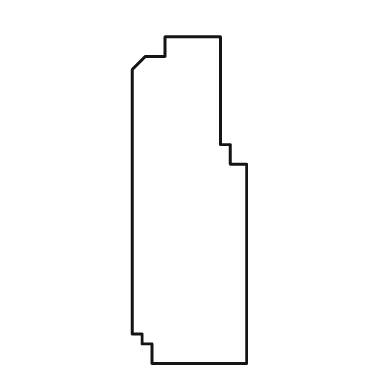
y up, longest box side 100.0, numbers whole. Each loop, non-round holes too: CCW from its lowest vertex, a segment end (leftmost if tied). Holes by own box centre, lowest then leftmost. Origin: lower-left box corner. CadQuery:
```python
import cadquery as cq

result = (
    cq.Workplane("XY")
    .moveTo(6.0, 0.0)
    .lineTo(35.0, 0.0)
    .lineTo(35.0, 61.0)
    .lineTo(30.0, 61.0)
    .lineTo(30.0, 67.0)
    .lineTo(27.0, 67.0)
    .lineTo(27.0, 100.0)
    .lineTo(10.0, 100.0)
    .lineTo(10.0, 94.0)
    .lineTo(4.0, 94.0)
    .lineTo(0.0, 90.0)
    .lineTo(0.0, 9.0)
    .lineTo(3.0, 9.0)
    .lineTo(3.0, 6.0)
    .lineTo(6.0, 6.0)
    .close()
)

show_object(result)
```